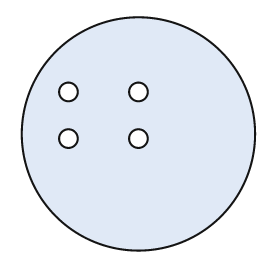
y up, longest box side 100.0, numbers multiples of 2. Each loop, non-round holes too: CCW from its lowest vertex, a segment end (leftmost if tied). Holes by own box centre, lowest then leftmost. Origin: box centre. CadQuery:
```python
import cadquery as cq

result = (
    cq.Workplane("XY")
    .moveTo(0.0, 0.0)
    .circle(50.0)
    .moveTo(-30.0, -2.0)
    .circle(4.0)
    .moveTo(0.0, -2.0)
    .circle(4.0)
    .moveTo(-30.0, 18.0)
    .circle(4.0)
    .moveTo(0.0, 18.0)
    .circle(4.0)
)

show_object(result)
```